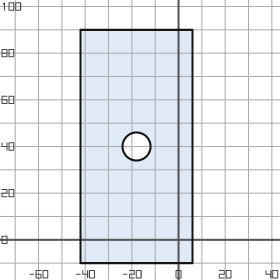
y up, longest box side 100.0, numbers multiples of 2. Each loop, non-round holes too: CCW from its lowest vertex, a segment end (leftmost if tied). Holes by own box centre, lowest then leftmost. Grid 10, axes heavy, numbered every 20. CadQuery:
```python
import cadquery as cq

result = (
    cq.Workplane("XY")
    .moveTo(-42.0, -10.0)
    .lineTo(6.0, -10.0)
    .lineTo(6.0, 90.0)
    .lineTo(-42.0, 90.0)
    .close()
    .moveTo(-18.0, 40.0)
    .circle(6.0)
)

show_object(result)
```